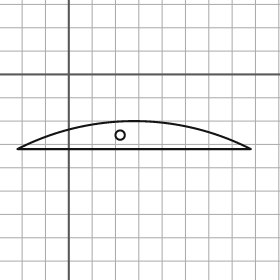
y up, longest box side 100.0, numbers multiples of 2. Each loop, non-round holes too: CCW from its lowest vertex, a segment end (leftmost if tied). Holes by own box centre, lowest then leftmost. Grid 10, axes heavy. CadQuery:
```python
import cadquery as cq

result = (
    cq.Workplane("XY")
    .moveTo(-22.0, -32.0)
    .lineTo(78.0, -32.0)
    .threePointArc((28.0, -20.0), (-22.0, -32.0))
    .close()
    .moveTo(22.0, -26.0)
    .circle(2.0)
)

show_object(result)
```